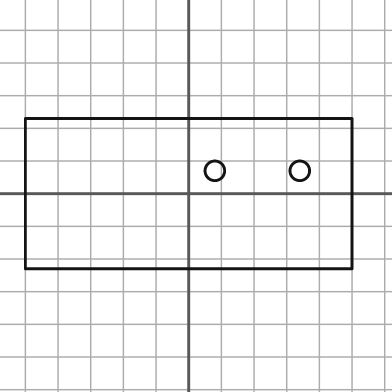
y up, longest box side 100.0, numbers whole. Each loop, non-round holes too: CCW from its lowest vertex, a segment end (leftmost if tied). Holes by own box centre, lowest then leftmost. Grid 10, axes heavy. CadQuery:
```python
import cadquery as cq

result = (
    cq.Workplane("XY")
    .moveTo(-50.0, -23.0)
    .lineTo(50.0, -23.0)
    .lineTo(50.0, 23.0)
    .lineTo(-50.0, 23.0)
    .close()
    .moveTo(8.0, 7.0)
    .circle(3.0)
    .moveTo(34.0, 7.0)
    .circle(3.0)
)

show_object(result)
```